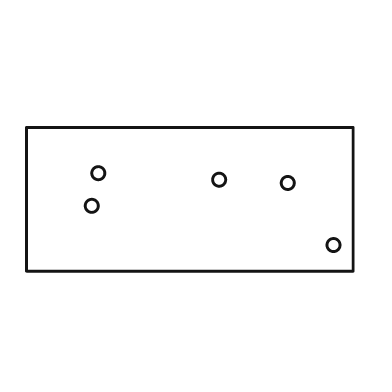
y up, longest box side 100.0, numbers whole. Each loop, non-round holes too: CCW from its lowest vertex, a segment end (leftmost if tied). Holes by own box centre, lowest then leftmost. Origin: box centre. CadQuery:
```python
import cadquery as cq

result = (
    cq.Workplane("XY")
    .moveTo(-50.0, -22.0)
    .lineTo(50.0, -22.0)
    .lineTo(50.0, 22.0)
    .lineTo(-50.0, 22.0)
    .close()
    .moveTo(44.0, -14.0)
    .circle(2.0)
    .moveTo(-30.0, -2.0)
    .circle(2.0)
    .moveTo(30.0, 5.0)
    .circle(2.0)
    .moveTo(9.0, 6.0)
    .circle(2.0)
    .moveTo(-28.0, 8.0)
    .circle(2.0)
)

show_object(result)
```